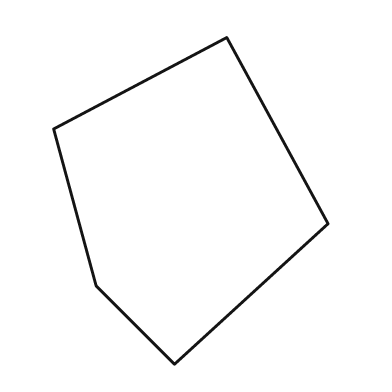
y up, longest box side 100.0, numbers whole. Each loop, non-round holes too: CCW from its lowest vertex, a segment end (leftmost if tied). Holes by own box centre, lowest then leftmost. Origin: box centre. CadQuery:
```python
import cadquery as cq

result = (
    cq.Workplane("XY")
    .moveTo(-5.0, -50.0)
    .lineTo(42.0, -7.0)
    .lineTo(11.0, 50.0)
    .lineTo(-42.0, 22.0)
    .lineTo(-29.0, -26.0)
    .close()
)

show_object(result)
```